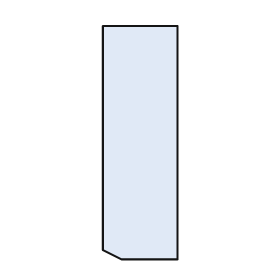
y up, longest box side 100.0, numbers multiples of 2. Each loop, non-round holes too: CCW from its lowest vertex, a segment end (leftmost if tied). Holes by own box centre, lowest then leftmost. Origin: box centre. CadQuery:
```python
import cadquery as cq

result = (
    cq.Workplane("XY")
    .moveTo(-8.0, -50.0)
    .lineTo(16.0, -50.0)
    .lineTo(16.0, 50.0)
    .lineTo(-16.0, 50.0)
    .lineTo(-16.0, -46.0)
    .close()
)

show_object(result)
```